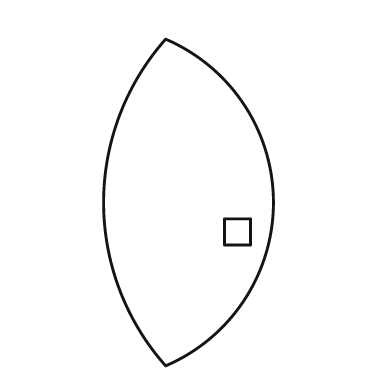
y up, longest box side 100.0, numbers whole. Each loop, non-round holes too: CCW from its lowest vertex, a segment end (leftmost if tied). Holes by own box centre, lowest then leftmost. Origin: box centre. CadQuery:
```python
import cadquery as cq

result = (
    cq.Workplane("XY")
    .moveTo(-7.0, -50.0)
    .threePointArc((26.0, 0.0), (-7.0, 50.0))
    .threePointArc((-26.0, 0.0), (-7.0, -50.0))
    .close()
    .moveTo(11.0, -13.0)
    .lineTo(19.0, -13.0)
    .lineTo(19.0, -5.0)
    .lineTo(11.0, -5.0)
    .close()
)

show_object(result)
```